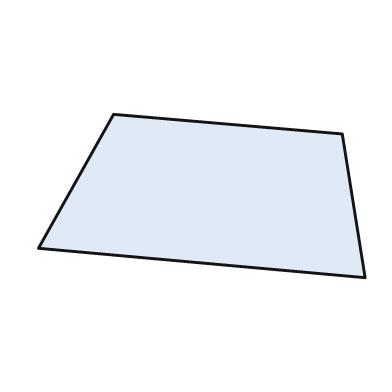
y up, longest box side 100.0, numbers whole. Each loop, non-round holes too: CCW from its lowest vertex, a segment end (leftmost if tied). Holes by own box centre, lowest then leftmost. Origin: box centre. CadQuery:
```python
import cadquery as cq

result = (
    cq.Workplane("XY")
    .moveTo(50.0, -25.0)
    .lineTo(43.0, 19.0)
    .lineTo(-27.0, 25.0)
    .lineTo(-50.0, -16.0)
    .close()
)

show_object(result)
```